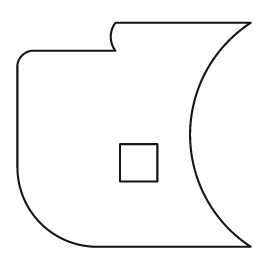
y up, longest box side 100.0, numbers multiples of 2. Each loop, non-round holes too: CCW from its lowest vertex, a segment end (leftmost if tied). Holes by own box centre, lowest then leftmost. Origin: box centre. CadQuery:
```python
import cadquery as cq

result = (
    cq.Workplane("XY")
    .moveTo(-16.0, -48.0)
    .lineTo(50.0, -48.0)
    .threePointArc((24.0, 0.0), (50.0, 48.0))
    .lineTo(-8.0, 48.0)
    .threePointArc((-10.0, 42.0), (-8.0, 36.0))
    .lineTo(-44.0, 36.0)
    .threePointArc((-48.0, 34.0), (-50.0, 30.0))
    .lineTo(-50.0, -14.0)
    .threePointArc((-40.0, -38.0), (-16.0, -48.0))
    .close()
    .moveTo(-6.0, -20.0)
    .lineTo(10.0, -20.0)
    .lineTo(10.0, -4.0)
    .lineTo(-6.0, -4.0)
    .close()
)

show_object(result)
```